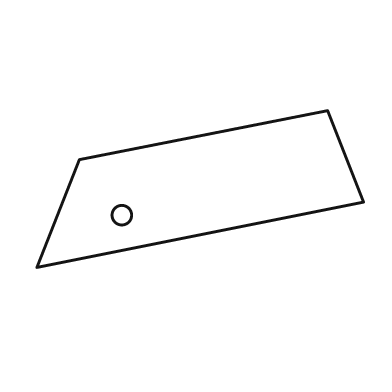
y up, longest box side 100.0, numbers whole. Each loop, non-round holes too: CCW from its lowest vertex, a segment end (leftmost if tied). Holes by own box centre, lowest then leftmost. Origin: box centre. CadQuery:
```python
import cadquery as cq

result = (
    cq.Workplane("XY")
    .moveTo(-50.0, -24.0)
    .lineTo(50.0, -4.0)
    .lineTo(39.0, 24.0)
    .lineTo(-37.0, 9.0)
    .close()
    .moveTo(-24.0, -8.0)
    .circle(3.0)
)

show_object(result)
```